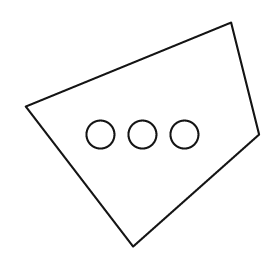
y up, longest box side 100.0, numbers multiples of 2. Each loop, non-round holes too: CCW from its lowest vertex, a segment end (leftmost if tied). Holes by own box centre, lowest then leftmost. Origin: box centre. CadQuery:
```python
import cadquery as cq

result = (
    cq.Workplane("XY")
    .moveTo(-4.0, -48.0)
    .lineTo(50.0, 0.0)
    .lineTo(38.0, 48.0)
    .lineTo(-50.0, 12.0)
    .close()
    .moveTo(-18.0, 0.0)
    .circle(6.0)
    .moveTo(0.0, 0.0)
    .circle(6.0)
    .moveTo(18.0, 0.0)
    .circle(6.0)
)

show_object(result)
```